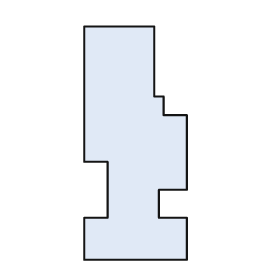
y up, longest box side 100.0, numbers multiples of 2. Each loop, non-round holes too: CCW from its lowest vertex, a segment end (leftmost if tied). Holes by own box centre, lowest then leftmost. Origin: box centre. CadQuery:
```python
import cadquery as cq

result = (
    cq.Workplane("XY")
    .moveTo(-22.0, -50.0)
    .lineTo(22.0, -50.0)
    .lineTo(22.0, -32.0)
    .lineTo(10.0, -32.0)
    .lineTo(10.0, -20.0)
    .lineTo(22.0, -20.0)
    .lineTo(22.0, 12.0)
    .lineTo(12.0, 12.0)
    .lineTo(12.0, 20.0)
    .lineTo(8.0, 20.0)
    .lineTo(8.0, 50.0)
    .lineTo(-22.0, 50.0)
    .lineTo(-22.0, -8.0)
    .lineTo(-12.0, -8.0)
    .lineTo(-12.0, -32.0)
    .lineTo(-22.0, -32.0)
    .close()
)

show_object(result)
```